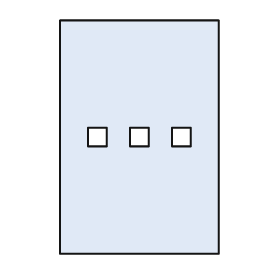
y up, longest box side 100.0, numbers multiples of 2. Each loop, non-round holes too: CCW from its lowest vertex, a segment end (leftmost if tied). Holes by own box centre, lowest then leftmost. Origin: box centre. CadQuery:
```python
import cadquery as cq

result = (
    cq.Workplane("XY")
    .moveTo(-34.0, -50.0)
    .lineTo(34.0, -50.0)
    .lineTo(34.0, 50.0)
    .lineTo(-34.0, 50.0)
    .close()
    .moveTo(-22.0, -4.0)
    .lineTo(-14.0, -4.0)
    .lineTo(-14.0, 4.0)
    .lineTo(-22.0, 4.0)
    .close()
    .moveTo(-4.0, -4.0)
    .lineTo(4.0, -4.0)
    .lineTo(4.0, 4.0)
    .lineTo(-4.0, 4.0)
    .close()
    .moveTo(14.0, -4.0)
    .lineTo(22.0, -4.0)
    .lineTo(22.0, 4.0)
    .lineTo(14.0, 4.0)
    .close()
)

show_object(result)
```